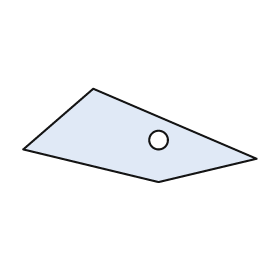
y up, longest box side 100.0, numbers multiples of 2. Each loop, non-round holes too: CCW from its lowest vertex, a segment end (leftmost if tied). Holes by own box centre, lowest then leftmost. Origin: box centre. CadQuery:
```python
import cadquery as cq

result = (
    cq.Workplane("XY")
    .moveTo(8.0, -20.0)
    .lineTo(50.0, -10.0)
    .lineTo(-20.0, 20.0)
    .lineTo(-50.0, -6.0)
    .close()
    .moveTo(8.0, -2.0)
    .circle(4.0)
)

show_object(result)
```